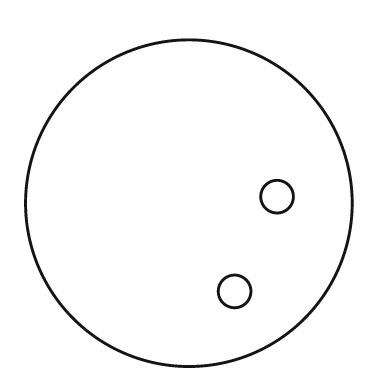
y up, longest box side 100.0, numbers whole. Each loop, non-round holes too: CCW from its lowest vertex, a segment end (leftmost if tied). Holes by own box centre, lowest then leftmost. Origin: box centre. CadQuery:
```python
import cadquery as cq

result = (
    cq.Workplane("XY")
    .moveTo(0.0, 0.0)
    .circle(50.0)
    .moveTo(14.0, -27.0)
    .circle(5.0)
    .moveTo(27.0, 2.0)
    .circle(5.0)
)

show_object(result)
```